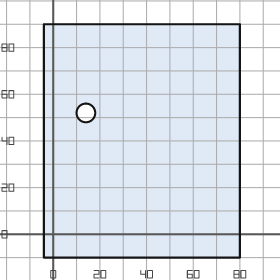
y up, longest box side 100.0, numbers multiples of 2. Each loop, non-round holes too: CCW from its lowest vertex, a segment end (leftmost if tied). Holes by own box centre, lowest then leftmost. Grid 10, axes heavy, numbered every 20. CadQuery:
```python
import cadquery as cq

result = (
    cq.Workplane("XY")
    .moveTo(-4.0, -10.0)
    .lineTo(80.0, -10.0)
    .lineTo(80.0, 90.0)
    .lineTo(-4.0, 90.0)
    .close()
    .moveTo(14.0, 52.0)
    .circle(4.0)
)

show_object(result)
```